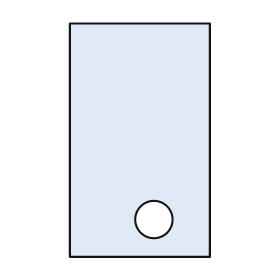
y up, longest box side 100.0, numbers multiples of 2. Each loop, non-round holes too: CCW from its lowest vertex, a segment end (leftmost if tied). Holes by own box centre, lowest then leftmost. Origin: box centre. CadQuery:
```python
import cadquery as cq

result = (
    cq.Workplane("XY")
    .moveTo(-30.0, -50.0)
    .lineTo(30.0, -50.0)
    .lineTo(30.0, 50.0)
    .lineTo(-30.0, 50.0)
    .close()
    .moveTo(6.0, -34.0)
    .circle(8.0)
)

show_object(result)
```